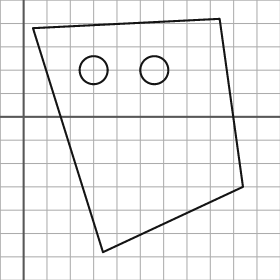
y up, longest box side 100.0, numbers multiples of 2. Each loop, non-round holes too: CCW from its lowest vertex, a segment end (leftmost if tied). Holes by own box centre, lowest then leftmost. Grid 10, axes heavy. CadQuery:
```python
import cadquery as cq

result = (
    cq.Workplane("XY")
    .moveTo(34.0, -58.0)
    .lineTo(94.0, -30.0)
    .lineTo(84.0, 42.0)
    .lineTo(4.0, 38.0)
    .close()
    .moveTo(30.0, 20.0)
    .circle(6.0)
    .moveTo(56.0, 20.0)
    .circle(6.0)
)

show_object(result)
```